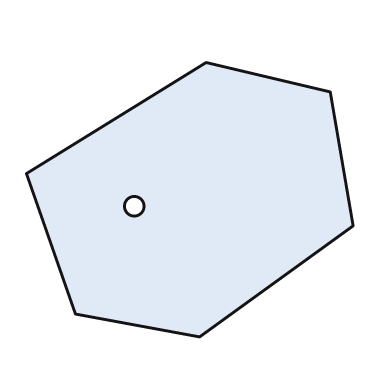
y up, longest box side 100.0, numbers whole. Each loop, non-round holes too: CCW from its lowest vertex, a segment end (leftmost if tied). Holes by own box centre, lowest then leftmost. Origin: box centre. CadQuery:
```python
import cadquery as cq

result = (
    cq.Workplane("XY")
    .moveTo(3.0, -42.0)
    .lineTo(50.0, -8.0)
    .lineTo(43.0, 33.0)
    .lineTo(5.0, 42.0)
    .lineTo(-50.0, 8.0)
    .lineTo(-35.0, -35.0)
    .close()
    .moveTo(-17.0, -2.0)
    .circle(3.0)
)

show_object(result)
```